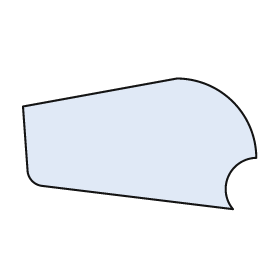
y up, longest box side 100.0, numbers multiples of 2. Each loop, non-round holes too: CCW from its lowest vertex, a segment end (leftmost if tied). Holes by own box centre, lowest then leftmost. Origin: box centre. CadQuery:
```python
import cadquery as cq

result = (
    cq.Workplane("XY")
    .moveTo(40.0, -28.0)
    .threePointArc((38.0, -14.0), (50.0, -6.0))
    .threePointArc((40.0, 18.0), (16.0, 28.0))
    .lineTo(-50.0, 16.0)
    .lineTo(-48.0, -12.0)
    .threePointArc((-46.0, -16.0), (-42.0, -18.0))
    .close()
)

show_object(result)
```